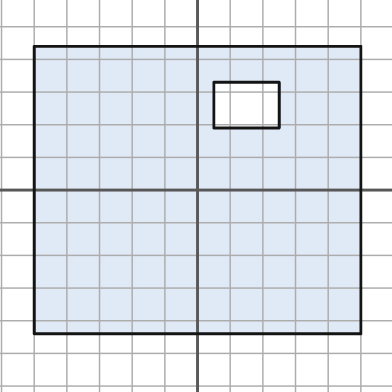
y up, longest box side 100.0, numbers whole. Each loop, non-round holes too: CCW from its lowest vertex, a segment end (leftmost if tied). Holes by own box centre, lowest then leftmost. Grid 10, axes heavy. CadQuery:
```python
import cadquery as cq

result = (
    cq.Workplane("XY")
    .moveTo(-50.0, -44.0)
    .lineTo(50.0, -44.0)
    .lineTo(50.0, 44.0)
    .lineTo(-50.0, 44.0)
    .close()
    .moveTo(5.0, 19.0)
    .lineTo(25.0, 19.0)
    .lineTo(25.0, 33.0)
    .lineTo(5.0, 33.0)
    .close()
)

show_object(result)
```